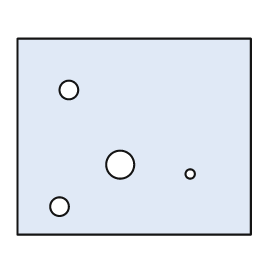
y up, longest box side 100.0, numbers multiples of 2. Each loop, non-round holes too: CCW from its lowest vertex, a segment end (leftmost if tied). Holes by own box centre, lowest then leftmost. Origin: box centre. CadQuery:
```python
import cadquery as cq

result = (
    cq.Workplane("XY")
    .moveTo(-50.0, -42.0)
    .lineTo(50.0, -42.0)
    .lineTo(50.0, 42.0)
    .lineTo(-50.0, 42.0)
    .close()
    .moveTo(-32.0, -30.0)
    .circle(4.0)
    .moveTo(24.0, -16.0)
    .circle(2.0)
    .moveTo(-6.0, -12.0)
    .circle(6.0)
    .moveTo(-28.0, 20.0)
    .circle(4.0)
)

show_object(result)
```